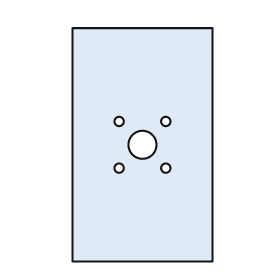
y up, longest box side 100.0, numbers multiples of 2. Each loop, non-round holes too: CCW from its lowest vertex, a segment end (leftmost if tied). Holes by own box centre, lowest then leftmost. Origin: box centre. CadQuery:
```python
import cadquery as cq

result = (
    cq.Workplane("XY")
    .moveTo(-30.0, -50.0)
    .lineTo(30.0, -50.0)
    .lineTo(30.0, 50.0)
    .lineTo(-30.0, 50.0)
    .close()
    .moveTo(-10.0, -10.0)
    .circle(2.0)
    .moveTo(10.0, -10.0)
    .circle(2.0)
    .moveTo(0.0, 0.0)
    .circle(6.0)
    .moveTo(-10.0, 10.0)
    .circle(2.0)
    .moveTo(10.0, 10.0)
    .circle(2.0)
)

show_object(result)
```